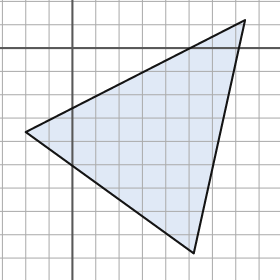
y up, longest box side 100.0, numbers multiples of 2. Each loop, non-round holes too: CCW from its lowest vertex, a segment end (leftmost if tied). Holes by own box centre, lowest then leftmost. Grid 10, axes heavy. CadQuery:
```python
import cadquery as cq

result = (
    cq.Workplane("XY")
    .moveTo(52.0, -88.0)
    .lineTo(74.0, 12.0)
    .lineTo(-20.0, -36.0)
    .close()
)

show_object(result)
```